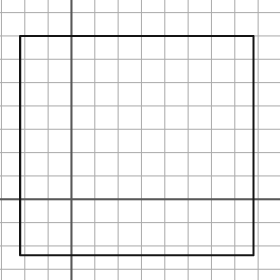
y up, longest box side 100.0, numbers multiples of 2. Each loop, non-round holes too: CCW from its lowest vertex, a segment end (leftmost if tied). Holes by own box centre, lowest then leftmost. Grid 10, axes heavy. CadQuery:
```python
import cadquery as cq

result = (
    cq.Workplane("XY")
    .moveTo(-22.0, -24.0)
    .lineTo(78.0, -24.0)
    .lineTo(78.0, 70.0)
    .lineTo(-22.0, 70.0)
    .close()
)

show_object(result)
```